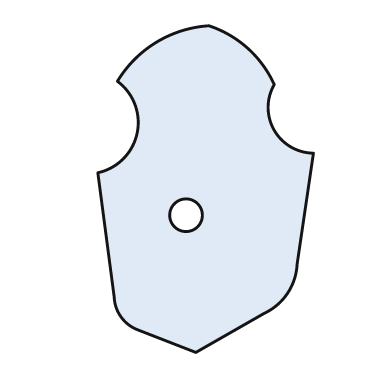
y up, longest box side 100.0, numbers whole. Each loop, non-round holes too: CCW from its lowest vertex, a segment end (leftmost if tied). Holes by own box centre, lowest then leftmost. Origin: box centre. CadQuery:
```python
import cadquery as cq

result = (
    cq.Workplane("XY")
    .moveTo(-3.0, -50.0)
    .lineTo(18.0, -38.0)
    .threePointArc((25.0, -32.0), (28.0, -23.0))
    .lineTo(33.0, 11.0)
    .threePointArc((21.0, 18.0), (21.0, 32.0))
    .threePointArc((13.0, 43.0), (1.0, 50.0))
    .threePointArc((-15.0, 45.0), (-27.0, 33.0))
    .threePointArc((-21.0, 17.0), (-33.0, 5.0))
    .lineTo(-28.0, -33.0)
    .threePointArc((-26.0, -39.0), (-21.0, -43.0))
    .close()
    .moveTo(-6.0, -8.0)
    .circle(5.0)
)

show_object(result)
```